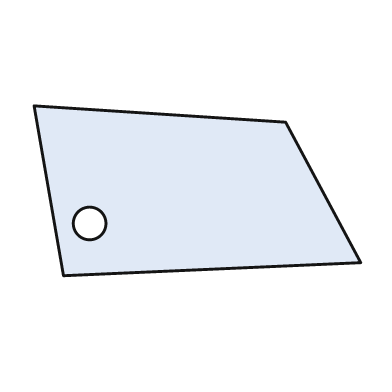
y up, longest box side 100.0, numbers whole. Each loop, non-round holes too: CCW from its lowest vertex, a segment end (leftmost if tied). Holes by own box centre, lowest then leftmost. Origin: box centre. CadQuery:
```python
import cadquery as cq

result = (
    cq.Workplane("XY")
    .moveTo(-41.0, -26.0)
    .lineTo(50.0, -22.0)
    .lineTo(27.0, 21.0)
    .lineTo(-50.0, 26.0)
    .close()
    .moveTo(-33.0, -10.0)
    .circle(5.0)
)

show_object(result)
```